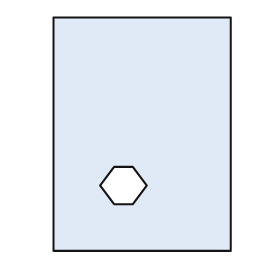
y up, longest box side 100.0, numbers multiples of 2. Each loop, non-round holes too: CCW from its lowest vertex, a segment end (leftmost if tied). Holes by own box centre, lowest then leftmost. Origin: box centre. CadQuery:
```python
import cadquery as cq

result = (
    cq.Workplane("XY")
    .moveTo(-38.0, -50.0)
    .lineTo(38.0, -50.0)
    .lineTo(38.0, 50.0)
    .lineTo(-38.0, 50.0)
    .close()
    .moveTo(-12.0, -30.0)
    .lineTo(-4.0, -30.0)
    .lineTo(2.0, -22.0)
    .lineTo(-4.0, -14.0)
    .lineTo(-12.0, -14.0)
    .lineTo(-18.0, -22.0)
    .close()
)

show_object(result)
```